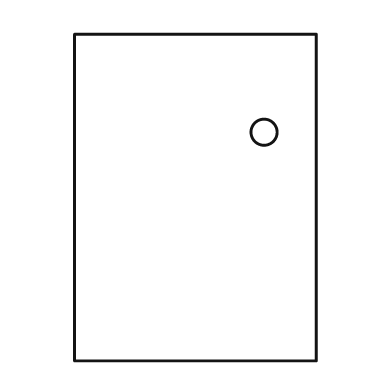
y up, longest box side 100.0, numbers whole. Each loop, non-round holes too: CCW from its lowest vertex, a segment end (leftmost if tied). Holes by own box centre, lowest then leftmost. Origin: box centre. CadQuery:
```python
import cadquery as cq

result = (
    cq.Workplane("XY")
    .moveTo(-37.0, -50.0)
    .lineTo(37.0, -50.0)
    .lineTo(37.0, 50.0)
    .lineTo(-37.0, 50.0)
    .close()
    .moveTo(21.0, 20.0)
    .circle(4.0)
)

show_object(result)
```